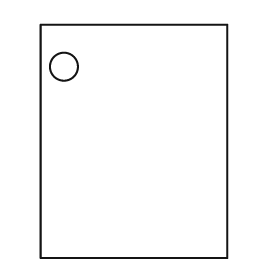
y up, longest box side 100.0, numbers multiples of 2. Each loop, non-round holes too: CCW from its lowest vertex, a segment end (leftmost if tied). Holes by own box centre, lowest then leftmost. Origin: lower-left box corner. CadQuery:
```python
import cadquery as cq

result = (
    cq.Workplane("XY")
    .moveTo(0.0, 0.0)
    .lineTo(80.0, 0.0)
    .lineTo(80.0, 100.0)
    .lineTo(0.0, 100.0)
    .close()
    .moveTo(10.0, 82.0)
    .circle(6.0)
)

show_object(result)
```